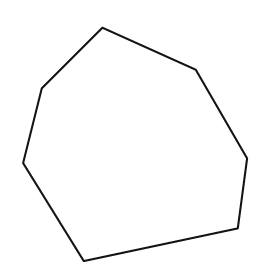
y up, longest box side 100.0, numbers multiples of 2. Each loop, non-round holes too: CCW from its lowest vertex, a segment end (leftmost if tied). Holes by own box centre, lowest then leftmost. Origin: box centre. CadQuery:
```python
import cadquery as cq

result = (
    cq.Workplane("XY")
    .moveTo(-22.0, -50.0)
    .lineTo(44.0, -36.0)
    .lineTo(48.0, -6.0)
    .lineTo(26.0, 32.0)
    .lineTo(-14.0, 50.0)
    .lineTo(-40.0, 24.0)
    .lineTo(-48.0, -8.0)
    .close()
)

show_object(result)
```